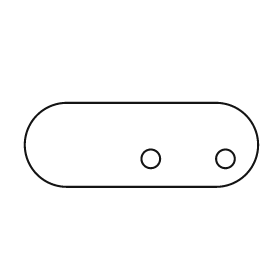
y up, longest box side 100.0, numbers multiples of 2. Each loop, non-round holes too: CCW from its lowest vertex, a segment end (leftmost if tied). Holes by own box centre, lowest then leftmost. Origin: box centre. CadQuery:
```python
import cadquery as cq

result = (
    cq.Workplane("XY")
    .moveTo(-32.0, -18.0)
    .lineTo(32.0, -18.0)
    .threePointArc((50.0, 0.0), (32.0, 18.0))
    .lineTo(-32.0, 18.0)
    .threePointArc((-50.0, 0.0), (-32.0, -18.0))
    .close()
    .moveTo(4.0, -6.0)
    .circle(4.0)
    .moveTo(36.0, -6.0)
    .circle(4.0)
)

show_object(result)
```